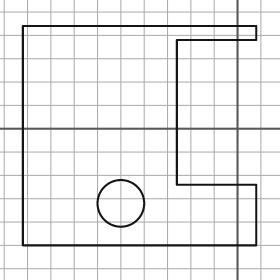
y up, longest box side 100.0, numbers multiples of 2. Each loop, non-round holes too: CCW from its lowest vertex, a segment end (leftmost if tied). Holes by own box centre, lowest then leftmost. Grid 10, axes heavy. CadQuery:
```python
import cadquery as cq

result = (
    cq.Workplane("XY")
    .moveTo(-92.0, -50.0)
    .lineTo(8.0, -50.0)
    .lineTo(8.0, -24.0)
    .lineTo(-26.0, -24.0)
    .lineTo(-26.0, 38.0)
    .lineTo(8.0, 38.0)
    .lineTo(8.0, 44.0)
    .lineTo(-92.0, 44.0)
    .close()
    .moveTo(-50.0, -32.0)
    .circle(10.0)
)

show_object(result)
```